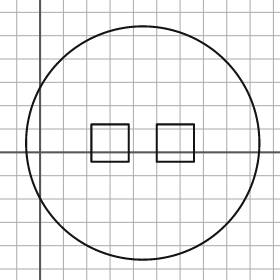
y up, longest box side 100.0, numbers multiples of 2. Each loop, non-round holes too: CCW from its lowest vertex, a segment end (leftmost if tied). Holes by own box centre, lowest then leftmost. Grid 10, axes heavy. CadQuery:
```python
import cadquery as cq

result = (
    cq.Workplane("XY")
    .moveTo(44.0, 4.0)
    .circle(50.0)
    .moveTo(22.0, -4.0)
    .lineTo(38.0, -4.0)
    .lineTo(38.0, 12.0)
    .lineTo(22.0, 12.0)
    .close()
    .moveTo(50.0, -4.0)
    .lineTo(66.0, -4.0)
    .lineTo(66.0, 12.0)
    .lineTo(50.0, 12.0)
    .close()
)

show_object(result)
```